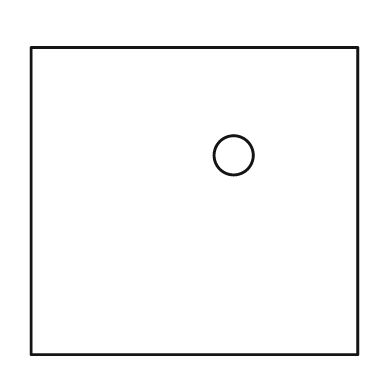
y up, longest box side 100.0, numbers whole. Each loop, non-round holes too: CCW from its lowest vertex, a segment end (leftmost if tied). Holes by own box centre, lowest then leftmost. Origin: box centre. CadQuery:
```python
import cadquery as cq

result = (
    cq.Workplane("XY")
    .moveTo(-50.0, -47.0)
    .lineTo(50.0, -47.0)
    .lineTo(50.0, 47.0)
    .lineTo(-50.0, 47.0)
    .close()
    .moveTo(12.0, 14.0)
    .circle(6.0)
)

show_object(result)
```